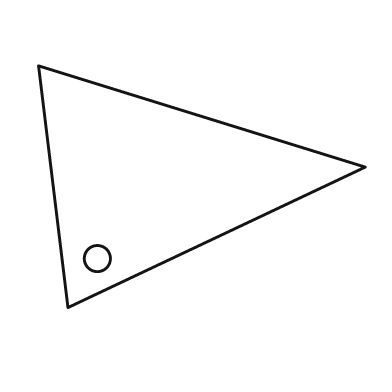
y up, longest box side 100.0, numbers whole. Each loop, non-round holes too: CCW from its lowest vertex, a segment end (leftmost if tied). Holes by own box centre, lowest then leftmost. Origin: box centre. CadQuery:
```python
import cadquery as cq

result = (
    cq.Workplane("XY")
    .moveTo(-41.0, -37.0)
    .lineTo(50.0, 6.0)
    .lineTo(-50.0, 37.0)
    .close()
    .moveTo(-32.0, -22.0)
    .circle(4.0)
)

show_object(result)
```